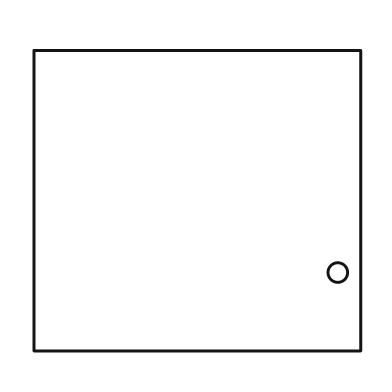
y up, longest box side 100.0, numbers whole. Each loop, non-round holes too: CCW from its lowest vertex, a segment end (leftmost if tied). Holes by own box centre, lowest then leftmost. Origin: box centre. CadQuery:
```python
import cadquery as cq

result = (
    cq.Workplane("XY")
    .moveTo(-50.0, -46.0)
    .lineTo(50.0, -46.0)
    .lineTo(50.0, 46.0)
    .lineTo(-50.0, 46.0)
    .close()
    .moveTo(43.0, -22.0)
    .circle(3.0)
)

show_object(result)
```